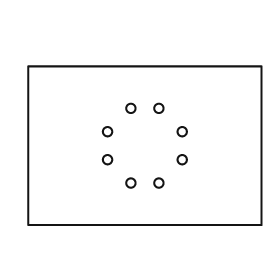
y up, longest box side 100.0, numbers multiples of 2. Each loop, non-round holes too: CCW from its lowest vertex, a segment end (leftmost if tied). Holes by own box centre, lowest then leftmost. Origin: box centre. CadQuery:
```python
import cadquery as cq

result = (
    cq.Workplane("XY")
    .moveTo(-50.0, -34.0)
    .lineTo(50.0, -34.0)
    .lineTo(50.0, 34.0)
    .lineTo(-50.0, 34.0)
    .close()
    .moveTo(-6.0, -16.0)
    .circle(2.0)
    .moveTo(6.0, -16.0)
    .circle(2.0)
    .moveTo(-16.0, -6.0)
    .circle(2.0)
    .moveTo(16.0, -6.0)
    .circle(2.0)
    .moveTo(-16.0, 6.0)
    .circle(2.0)
    .moveTo(16.0, 6.0)
    .circle(2.0)
    .moveTo(-6.0, 16.0)
    .circle(2.0)
    .moveTo(6.0, 16.0)
    .circle(2.0)
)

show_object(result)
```